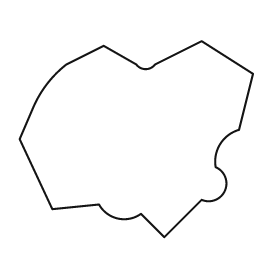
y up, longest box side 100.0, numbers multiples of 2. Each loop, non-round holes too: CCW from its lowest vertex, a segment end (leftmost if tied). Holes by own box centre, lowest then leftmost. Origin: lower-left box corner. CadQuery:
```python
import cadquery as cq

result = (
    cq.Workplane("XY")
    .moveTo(62.0, 0.0)
    .lineTo(78.0, 16.0)
    .threePointArc((88.0, 20.0), (84.0, 30.0))
    .threePointArc((86.0, 40.0), (94.0, 46.0))
    .lineTo(100.0, 70.0)
    .lineTo(78.0, 84.0)
    .lineTo(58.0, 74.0)
    .threePointArc((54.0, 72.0), (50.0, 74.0))
    .lineTo(36.0, 82.0)
    .lineTo(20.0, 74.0)
    .threePointArc((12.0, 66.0), (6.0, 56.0))
    .lineTo(0.0, 42.0)
    .lineTo(14.0, 12.0)
    .lineTo(34.0, 14.0)
    .threePointArc((42.0, 8.0), (52.0, 10.0))
    .close()
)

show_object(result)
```